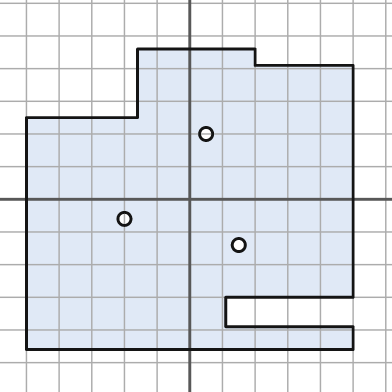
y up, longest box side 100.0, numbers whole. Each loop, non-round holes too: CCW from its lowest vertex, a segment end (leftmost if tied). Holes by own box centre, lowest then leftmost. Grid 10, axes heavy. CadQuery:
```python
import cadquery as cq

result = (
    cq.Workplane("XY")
    .moveTo(-50.0, -46.0)
    .lineTo(50.0, -46.0)
    .lineTo(50.0, -39.0)
    .lineTo(11.0, -39.0)
    .lineTo(11.0, -30.0)
    .lineTo(50.0, -30.0)
    .lineTo(50.0, 41.0)
    .lineTo(20.0, 41.0)
    .lineTo(20.0, 46.0)
    .lineTo(-16.0, 46.0)
    .lineTo(-16.0, 25.0)
    .lineTo(-50.0, 25.0)
    .close()
    .moveTo(15.0, -14.0)
    .circle(2.0)
    .moveTo(-20.0, -6.0)
    .circle(2.0)
    .moveTo(5.0, 20.0)
    .circle(2.0)
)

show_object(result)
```